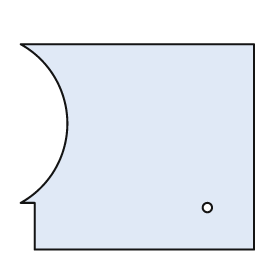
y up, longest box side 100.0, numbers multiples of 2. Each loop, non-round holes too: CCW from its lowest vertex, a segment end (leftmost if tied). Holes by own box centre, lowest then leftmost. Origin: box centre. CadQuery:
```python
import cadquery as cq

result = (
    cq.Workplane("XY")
    .moveTo(-44.0, -44.0)
    .lineTo(50.0, -44.0)
    .lineTo(50.0, 44.0)
    .lineTo(-50.0, 44.0)
    .threePointArc((-30.0, 10.0), (-50.0, -24.0))
    .lineTo(-44.0, -24.0)
    .close()
    .moveTo(30.0, -26.0)
    .circle(2.0)
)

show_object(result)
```